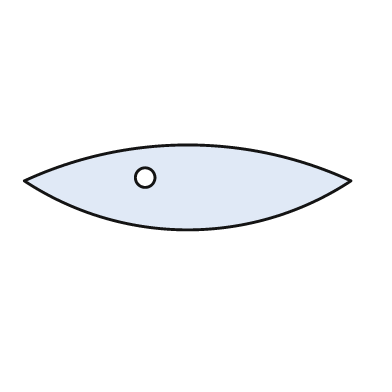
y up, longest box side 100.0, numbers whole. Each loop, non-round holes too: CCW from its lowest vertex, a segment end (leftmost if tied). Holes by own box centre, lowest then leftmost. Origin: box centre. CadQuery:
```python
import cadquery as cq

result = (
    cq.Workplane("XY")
    .moveTo(-50.0, 2.0)
    .threePointArc((0.0, -13.0), (50.0, 2.0))
    .threePointArc((0.0, 13.0), (-50.0, 2.0))
    .close()
    .moveTo(-13.0, 3.0)
    .circle(3.0)
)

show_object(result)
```